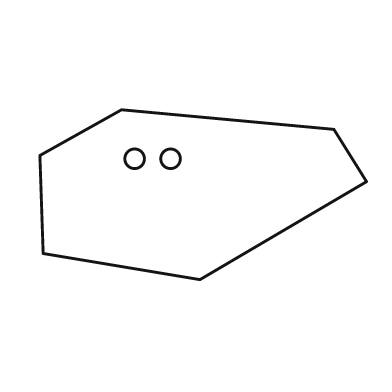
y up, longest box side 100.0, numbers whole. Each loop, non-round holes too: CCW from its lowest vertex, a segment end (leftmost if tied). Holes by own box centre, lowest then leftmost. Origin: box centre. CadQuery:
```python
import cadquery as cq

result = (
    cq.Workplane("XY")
    .moveTo(-1.0, -26.0)
    .lineTo(50.0, 4.0)
    .lineTo(40.0, 20.0)
    .lineTo(-25.0, 26.0)
    .lineTo(-50.0, 12.0)
    .lineTo(-49.0, -18.0)
    .close()
    .moveTo(-21.0, 11.0)
    .circle(3.0)
    .moveTo(-10.0, 11.0)
    .circle(3.0)
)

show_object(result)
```